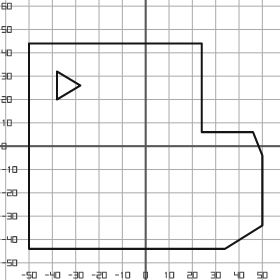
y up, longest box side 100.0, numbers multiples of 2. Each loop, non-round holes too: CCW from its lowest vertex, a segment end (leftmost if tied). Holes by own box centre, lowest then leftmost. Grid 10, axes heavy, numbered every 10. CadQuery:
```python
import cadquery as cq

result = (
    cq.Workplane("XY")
    .moveTo(-50.0, -44.0)
    .lineTo(34.0, -44.0)
    .lineTo(50.0, -34.0)
    .lineTo(50.0, -4.0)
    .lineTo(46.0, 6.0)
    .lineTo(24.0, 6.0)
    .lineTo(24.0, 44.0)
    .lineTo(-50.0, 44.0)
    .close()
    .moveTo(-38.0, 20.0)
    .lineTo(-28.0, 26.0)
    .lineTo(-38.0, 32.0)
    .close()
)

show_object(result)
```